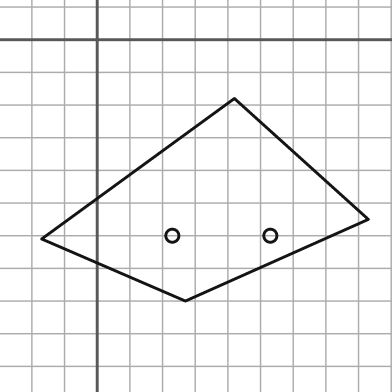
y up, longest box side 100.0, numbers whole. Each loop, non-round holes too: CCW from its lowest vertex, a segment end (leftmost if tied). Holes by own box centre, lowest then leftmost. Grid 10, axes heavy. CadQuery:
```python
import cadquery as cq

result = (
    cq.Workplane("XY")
    .moveTo(27.0, -80.0)
    .lineTo(83.0, -55.0)
    .lineTo(42.0, -18.0)
    .lineTo(-17.0, -61.0)
    .close()
    .moveTo(23.0, -60.0)
    .circle(2.0)
    .moveTo(53.0, -60.0)
    .circle(2.0)
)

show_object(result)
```